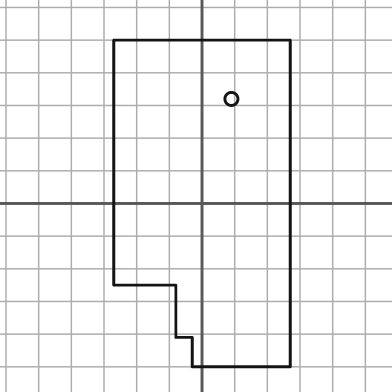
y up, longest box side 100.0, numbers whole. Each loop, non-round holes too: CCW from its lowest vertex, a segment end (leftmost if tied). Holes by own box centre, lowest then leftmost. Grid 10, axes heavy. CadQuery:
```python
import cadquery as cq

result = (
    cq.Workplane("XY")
    .moveTo(-3.0, -50.0)
    .lineTo(27.0, -50.0)
    .lineTo(27.0, 50.0)
    .lineTo(-27.0, 50.0)
    .lineTo(-27.0, -25.0)
    .lineTo(-8.0, -25.0)
    .lineTo(-8.0, -41.0)
    .lineTo(-3.0, -41.0)
    .close()
    .moveTo(9.0, 32.0)
    .circle(2.0)
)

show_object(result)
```